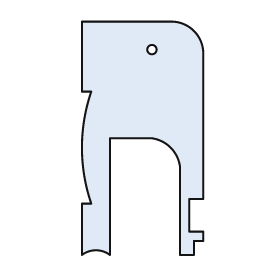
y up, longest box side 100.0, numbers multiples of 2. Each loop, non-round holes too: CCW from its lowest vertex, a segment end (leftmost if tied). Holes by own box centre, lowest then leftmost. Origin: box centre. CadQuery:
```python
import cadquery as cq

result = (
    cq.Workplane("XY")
    .moveTo(-26.0, -50.0)
    .threePointArc((-20.0, -48.0), (-14.0, -50.0))
    .lineTo(-14.0, 0.0)
    .lineTo(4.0, 0.0)
    .threePointArc((12.0, -4.0), (16.0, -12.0))
    .lineTo(16.0, -50.0)
    .lineTo(22.0, -50.0)
    .lineTo(22.0, -44.0)
    .lineTo(26.0, -44.0)
    .lineTo(26.0, -40.0)
    .lineTo(20.0, -40.0)
    .lineTo(20.0, -26.0)
    .lineTo(26.0, -26.0)
    .lineTo(26.0, 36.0)
    .threePointArc((22.0, 46.0), (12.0, 50.0))
    .lineTo(-26.0, 50.0)
    .lineTo(-26.0, 20.0)
    .lineTo(-22.0, 20.0)
    .threePointArc((-26.0, -4.0), (-22.0, -28.0))
    .lineTo(-26.0, -28.0)
    .close()
    .moveTo(4.0, 38.0)
    .circle(2.0)
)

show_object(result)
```